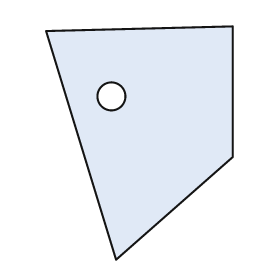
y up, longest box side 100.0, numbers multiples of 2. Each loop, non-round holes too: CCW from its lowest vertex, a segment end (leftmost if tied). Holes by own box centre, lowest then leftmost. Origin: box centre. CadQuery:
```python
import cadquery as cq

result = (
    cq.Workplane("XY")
    .moveTo(-10.0, -50.0)
    .lineTo(40.0, -6.0)
    .lineTo(40.0, 50.0)
    .lineTo(-40.0, 48.0)
    .close()
    .moveTo(-12.0, 20.0)
    .circle(6.0)
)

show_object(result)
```